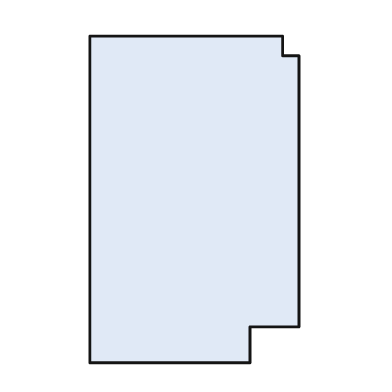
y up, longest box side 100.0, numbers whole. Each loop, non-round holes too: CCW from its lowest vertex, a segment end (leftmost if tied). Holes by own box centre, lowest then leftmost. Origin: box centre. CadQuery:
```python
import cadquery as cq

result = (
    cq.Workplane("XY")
    .moveTo(-32.0, -50.0)
    .lineTo(17.0, -50.0)
    .lineTo(17.0, -39.0)
    .lineTo(32.0, -39.0)
    .lineTo(32.0, 44.0)
    .lineTo(27.0, 44.0)
    .lineTo(27.0, 50.0)
    .lineTo(-32.0, 50.0)
    .close()
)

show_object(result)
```